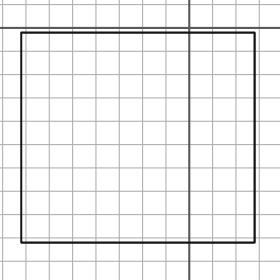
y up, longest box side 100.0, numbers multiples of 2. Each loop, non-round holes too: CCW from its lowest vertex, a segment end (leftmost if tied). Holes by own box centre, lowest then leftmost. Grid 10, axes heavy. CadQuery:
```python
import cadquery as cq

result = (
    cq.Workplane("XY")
    .moveTo(-72.0, -92.0)
    .lineTo(28.0, -92.0)
    .lineTo(28.0, -2.0)
    .lineTo(-72.0, -2.0)
    .close()
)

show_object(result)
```